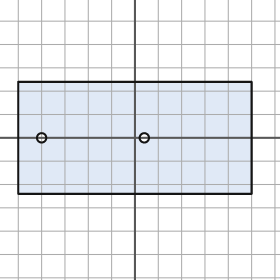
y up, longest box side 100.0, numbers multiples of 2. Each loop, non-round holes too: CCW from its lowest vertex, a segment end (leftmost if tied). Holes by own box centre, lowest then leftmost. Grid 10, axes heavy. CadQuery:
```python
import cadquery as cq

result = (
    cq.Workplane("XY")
    .moveTo(-50.0, -24.0)
    .lineTo(50.0, -24.0)
    .lineTo(50.0, 24.0)
    .lineTo(-50.0, 24.0)
    .close()
    .moveTo(-40.0, 0.0)
    .circle(2.0)
    .moveTo(4.0, 0.0)
    .circle(2.0)
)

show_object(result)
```